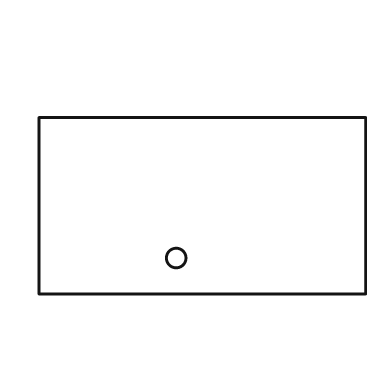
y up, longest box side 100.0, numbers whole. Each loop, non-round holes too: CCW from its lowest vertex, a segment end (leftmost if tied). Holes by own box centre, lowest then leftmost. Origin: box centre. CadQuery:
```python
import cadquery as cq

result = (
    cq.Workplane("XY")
    .moveTo(-50.0, -27.0)
    .lineTo(50.0, -27.0)
    .lineTo(50.0, 27.0)
    .lineTo(-50.0, 27.0)
    .close()
    .moveTo(-8.0, -16.0)
    .circle(3.0)
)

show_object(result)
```